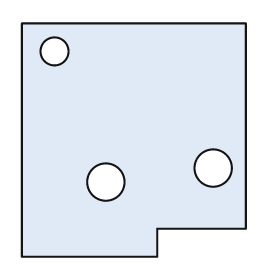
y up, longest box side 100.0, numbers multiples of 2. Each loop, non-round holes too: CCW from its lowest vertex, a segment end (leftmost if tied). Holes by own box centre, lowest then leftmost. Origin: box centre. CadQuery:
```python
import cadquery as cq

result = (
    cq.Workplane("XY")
    .moveTo(-48.0, -50.0)
    .lineTo(10.0, -50.0)
    .lineTo(10.0, -38.0)
    .lineTo(48.0, -38.0)
    .lineTo(48.0, 50.0)
    .lineTo(-48.0, 50.0)
    .close()
    .moveTo(-12.0, -18.0)
    .circle(8.0)
    .moveTo(34.0, -12.0)
    .circle(8.0)
    .moveTo(-34.0, 38.0)
    .circle(6.0)
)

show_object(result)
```